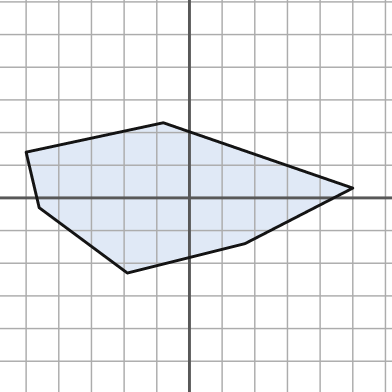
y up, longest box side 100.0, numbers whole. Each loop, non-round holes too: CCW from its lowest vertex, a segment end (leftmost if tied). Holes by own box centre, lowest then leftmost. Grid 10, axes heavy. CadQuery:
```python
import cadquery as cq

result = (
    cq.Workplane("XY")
    .moveTo(-19.0, -23.0)
    .lineTo(17.0, -14.0)
    .lineTo(50.0, 3.0)
    .lineTo(-8.0, 23.0)
    .lineTo(-50.0, 14.0)
    .lineTo(-46.0, -3.0)
    .close()
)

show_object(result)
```